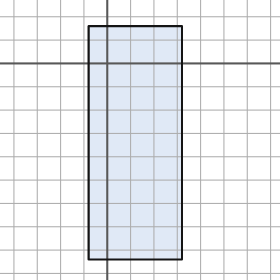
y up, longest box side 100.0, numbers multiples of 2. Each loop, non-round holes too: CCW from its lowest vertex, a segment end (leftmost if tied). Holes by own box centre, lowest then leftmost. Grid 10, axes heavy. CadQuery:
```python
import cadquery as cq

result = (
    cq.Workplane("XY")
    .moveTo(-8.0, -84.0)
    .lineTo(32.0, -84.0)
    .lineTo(32.0, 16.0)
    .lineTo(-8.0, 16.0)
    .close()
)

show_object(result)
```